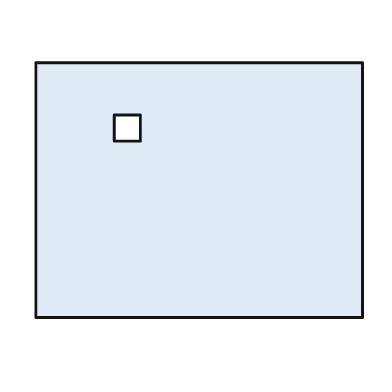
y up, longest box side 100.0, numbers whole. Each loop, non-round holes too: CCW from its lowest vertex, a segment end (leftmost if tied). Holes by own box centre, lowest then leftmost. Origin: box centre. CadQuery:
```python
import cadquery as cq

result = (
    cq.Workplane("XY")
    .moveTo(-50.0, -39.0)
    .lineTo(50.0, -39.0)
    .lineTo(50.0, 39.0)
    .lineTo(-50.0, 39.0)
    .close()
    .moveTo(-26.0, 15.0)
    .lineTo(-18.0, 15.0)
    .lineTo(-18.0, 23.0)
    .lineTo(-26.0, 23.0)
    .close()
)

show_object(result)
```